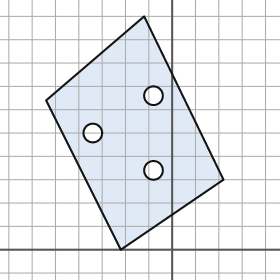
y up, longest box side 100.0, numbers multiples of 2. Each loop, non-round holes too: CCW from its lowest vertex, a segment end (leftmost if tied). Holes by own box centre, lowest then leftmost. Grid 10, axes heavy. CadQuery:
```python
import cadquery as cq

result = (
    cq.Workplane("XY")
    .moveTo(-22.0, 0.0)
    .lineTo(22.0, 30.0)
    .lineTo(-12.0, 100.0)
    .lineTo(-54.0, 64.0)
    .close()
    .moveTo(-8.0, 34.0)
    .circle(4.0)
    .moveTo(-34.0, 50.0)
    .circle(4.0)
    .moveTo(-8.0, 66.0)
    .circle(4.0)
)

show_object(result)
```